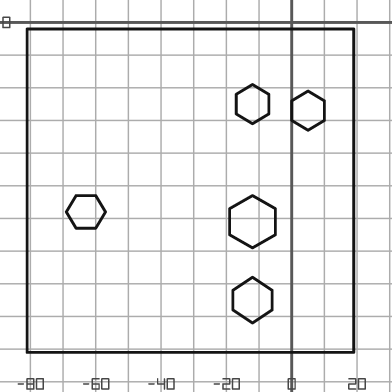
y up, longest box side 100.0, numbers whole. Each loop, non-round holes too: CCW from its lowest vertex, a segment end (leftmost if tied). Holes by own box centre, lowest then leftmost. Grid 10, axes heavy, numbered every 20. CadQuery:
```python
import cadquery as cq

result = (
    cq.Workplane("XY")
    .moveTo(-81.0, -101.0)
    .lineTo(19.0, -101.0)
    .lineTo(19.0, -2.0)
    .lineTo(-81.0, -2.0)
    .close()
    .moveTo(-12.0, -92.0)
    .lineTo(-6.0, -88.0)
    .lineTo(-6.0, -82.0)
    .lineTo(-12.0, -78.0)
    .lineTo(-18.0, -82.0)
    .lineTo(-18.0, -88.0)
    .close()
    .moveTo(-12.0, -69.0)
    .lineTo(-5.0, -65.0)
    .lineTo(-5.0, -57.0)
    .lineTo(-12.0, -53.0)
    .lineTo(-19.0, -57.0)
    .lineTo(-19.0, -65.0)
    .close()
    .moveTo(-66.0, -63.0)
    .lineTo(-60.0, -63.0)
    .lineTo(-57.0, -58.0)
    .lineTo(-60.0, -53.0)
    .lineTo(-66.0, -53.0)
    .lineTo(-69.0, -58.0)
    .close()
    .moveTo(5.0, -33.0)
    .lineTo(10.0, -30.0)
    .lineTo(10.0, -24.0)
    .lineTo(5.0, -21.0)
    .lineTo(0.0, -24.0)
    .lineTo(0.0, -30.0)
    .close()
    .moveTo(-12.0, -31.0)
    .lineTo(-7.0, -28.0)
    .lineTo(-7.0, -22.0)
    .lineTo(-12.0, -19.0)
    .lineTo(-17.0, -22.0)
    .lineTo(-17.0, -28.0)
    .close()
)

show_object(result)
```